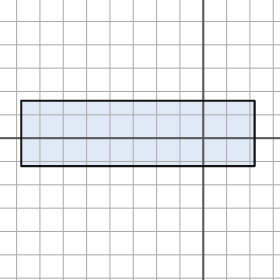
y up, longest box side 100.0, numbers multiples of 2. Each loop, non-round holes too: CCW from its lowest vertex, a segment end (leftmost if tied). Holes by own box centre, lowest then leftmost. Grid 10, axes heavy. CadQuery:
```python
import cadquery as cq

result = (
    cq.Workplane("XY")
    .moveTo(-78.0, -12.0)
    .lineTo(22.0, -12.0)
    .lineTo(22.0, 16.0)
    .lineTo(-78.0, 16.0)
    .close()
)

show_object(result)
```